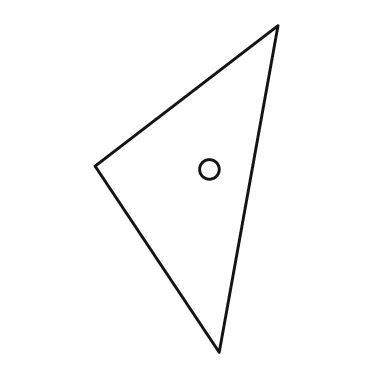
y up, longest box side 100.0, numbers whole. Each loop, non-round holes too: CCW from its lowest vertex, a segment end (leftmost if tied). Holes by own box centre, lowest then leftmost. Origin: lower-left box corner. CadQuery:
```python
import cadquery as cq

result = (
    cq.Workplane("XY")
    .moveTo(38.0, 0.0)
    .lineTo(56.0, 100.0)
    .lineTo(0.0, 57.0)
    .close()
    .moveTo(35.0, 56.0)
    .circle(3.0)
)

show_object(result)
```